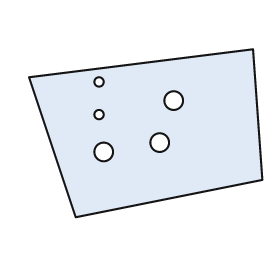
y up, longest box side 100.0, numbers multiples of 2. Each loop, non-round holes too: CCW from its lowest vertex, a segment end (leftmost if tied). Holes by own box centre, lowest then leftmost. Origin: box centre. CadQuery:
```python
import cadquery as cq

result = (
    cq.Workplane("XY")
    .moveTo(-30.0, -36.0)
    .lineTo(50.0, -20.0)
    .lineTo(46.0, 36.0)
    .lineTo(-50.0, 24.0)
    .close()
    .moveTo(-18.0, -8.0)
    .circle(4.0)
    .moveTo(6.0, -4.0)
    .circle(4.0)
    .moveTo(-20.0, 8.0)
    .circle(2.0)
    .moveTo(12.0, 14.0)
    .circle(4.0)
    .moveTo(-20.0, 22.0)
    .circle(2.0)
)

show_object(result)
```